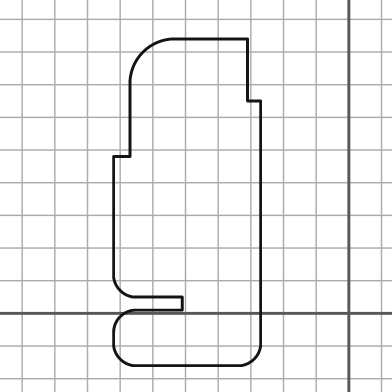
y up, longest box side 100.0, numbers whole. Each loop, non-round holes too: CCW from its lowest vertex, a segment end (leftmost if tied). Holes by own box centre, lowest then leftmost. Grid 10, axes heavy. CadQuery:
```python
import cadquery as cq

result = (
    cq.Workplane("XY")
    .moveTo(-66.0, -16.0)
    .lineTo(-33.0, -16.0)
    .threePointArc((-29.0, -14.0), (-27.0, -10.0))
    .lineTo(-27.0, 65.0)
    .lineTo(-31.0, 65.0)
    .lineTo(-31.0, 84.0)
    .lineTo(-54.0, 84.0)
    .threePointArc((-63.0, 80.0), (-67.0, 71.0))
    .lineTo(-67.0, 48.0)
    .lineTo(-72.0, 48.0)
    .lineTo(-72.0, 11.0)
    .threePointArc((-70.0, 7.0), (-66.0, 5.0))
    .lineTo(-51.0, 5.0)
    .lineTo(-51.0, 1.0)
    .lineTo(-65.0, 1.0)
    .threePointArc((-70.0, -1.0), (-72.0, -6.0))
    .lineTo(-72.0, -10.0)
    .threePointArc((-70.0, -14.0), (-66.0, -16.0))
    .close()
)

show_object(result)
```